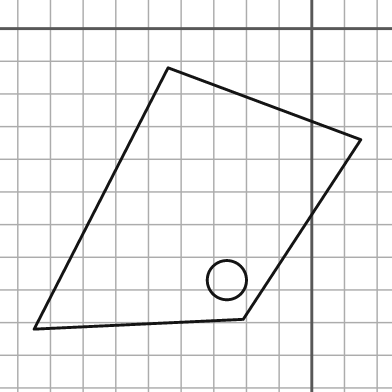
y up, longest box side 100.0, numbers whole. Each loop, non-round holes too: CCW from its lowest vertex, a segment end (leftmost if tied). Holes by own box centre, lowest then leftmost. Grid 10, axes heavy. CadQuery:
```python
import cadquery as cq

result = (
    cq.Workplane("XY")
    .moveTo(-85.0, -92.0)
    .lineTo(-21.0, -89.0)
    .lineTo(15.0, -34.0)
    .lineTo(-44.0, -12.0)
    .close()
    .moveTo(-26.0, -77.0)
    .circle(6.0)
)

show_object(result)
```